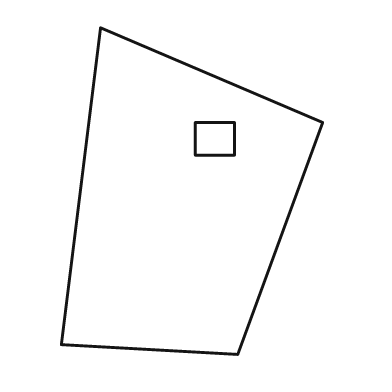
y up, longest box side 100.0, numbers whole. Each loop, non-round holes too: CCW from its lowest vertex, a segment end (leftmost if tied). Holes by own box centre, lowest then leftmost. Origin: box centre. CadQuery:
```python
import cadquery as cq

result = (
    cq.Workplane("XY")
    .moveTo(14.0, -50.0)
    .lineTo(40.0, 21.0)
    .lineTo(-28.0, 50.0)
    .lineTo(-40.0, -47.0)
    .close()
    .moveTo(1.0, 11.0)
    .lineTo(13.0, 11.0)
    .lineTo(13.0, 21.0)
    .lineTo(1.0, 21.0)
    .close()
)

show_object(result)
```